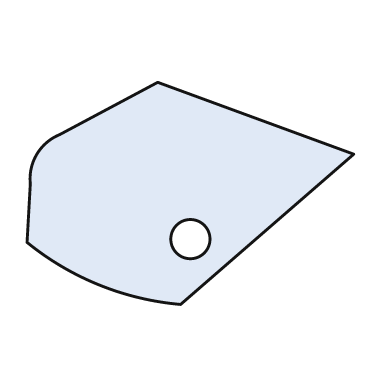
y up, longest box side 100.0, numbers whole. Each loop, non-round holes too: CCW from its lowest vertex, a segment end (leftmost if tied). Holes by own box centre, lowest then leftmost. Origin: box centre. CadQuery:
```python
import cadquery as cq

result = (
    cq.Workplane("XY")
    .moveTo(-3.0, -34.0)
    .lineTo(50.0, 12.0)
    .lineTo(-10.0, 34.0)
    .lineTo(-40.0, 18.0)
    .threePointArc((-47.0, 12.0), (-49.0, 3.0))
    .lineTo(-50.0, -15.0)
    .threePointArc((-28.0, -28.0), (-3.0, -34.0))
    .close()
    .moveTo(0.0, -14.0)
    .circle(6.0)
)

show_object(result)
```